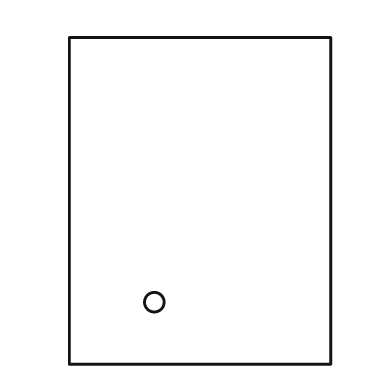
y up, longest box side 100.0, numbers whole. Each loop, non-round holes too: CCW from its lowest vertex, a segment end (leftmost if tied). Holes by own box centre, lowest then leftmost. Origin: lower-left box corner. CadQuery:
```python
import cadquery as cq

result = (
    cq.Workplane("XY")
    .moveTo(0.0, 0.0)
    .lineTo(80.0, 0.0)
    .lineTo(80.0, 100.0)
    .lineTo(0.0, 100.0)
    .close()
    .moveTo(26.0, 19.0)
    .circle(3.0)
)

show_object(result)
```